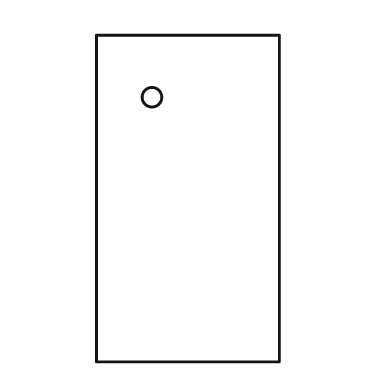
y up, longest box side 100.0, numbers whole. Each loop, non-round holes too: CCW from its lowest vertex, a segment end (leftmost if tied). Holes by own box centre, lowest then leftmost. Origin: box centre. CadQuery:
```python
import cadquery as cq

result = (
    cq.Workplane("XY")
    .moveTo(-28.0, -50.0)
    .lineTo(28.0, -50.0)
    .lineTo(28.0, 50.0)
    .lineTo(-28.0, 50.0)
    .close()
    .moveTo(-11.0, 31.0)
    .circle(3.0)
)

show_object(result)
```